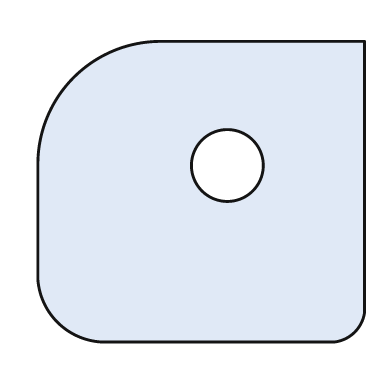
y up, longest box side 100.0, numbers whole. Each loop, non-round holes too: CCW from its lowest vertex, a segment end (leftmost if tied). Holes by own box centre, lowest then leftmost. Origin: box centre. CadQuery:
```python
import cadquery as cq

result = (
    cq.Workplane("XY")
    .moveTo(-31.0, -46.0)
    .lineTo(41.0, -46.0)
    .threePointArc((47.0, -43.0), (50.0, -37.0))
    .lineTo(50.0, 46.0)
    .lineTo(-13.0, 46.0)
    .threePointArc((-39.0, 35.0), (-50.0, 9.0))
    .lineTo(-50.0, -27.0)
    .threePointArc((-44.0, -40.0), (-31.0, -46.0))
    .close()
    .moveTo(8.0, 8.0)
    .circle(11.0)
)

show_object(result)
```